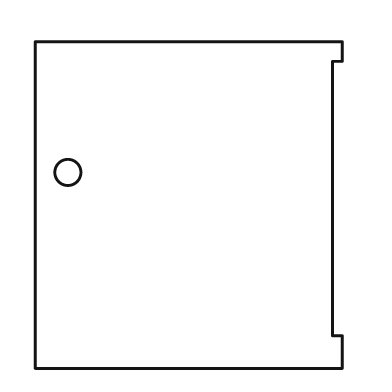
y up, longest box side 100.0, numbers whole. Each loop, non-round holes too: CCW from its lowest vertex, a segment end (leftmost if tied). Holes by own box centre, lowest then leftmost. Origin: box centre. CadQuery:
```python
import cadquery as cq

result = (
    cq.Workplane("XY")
    .moveTo(-47.0, -50.0)
    .lineTo(47.0, -50.0)
    .lineTo(47.0, -40.0)
    .lineTo(44.0, -40.0)
    .lineTo(44.0, 44.0)
    .lineTo(47.0, 44.0)
    .lineTo(47.0, 50.0)
    .lineTo(-47.0, 50.0)
    .close()
    .moveTo(-37.0, 10.0)
    .circle(4.0)
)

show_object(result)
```